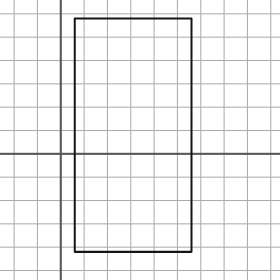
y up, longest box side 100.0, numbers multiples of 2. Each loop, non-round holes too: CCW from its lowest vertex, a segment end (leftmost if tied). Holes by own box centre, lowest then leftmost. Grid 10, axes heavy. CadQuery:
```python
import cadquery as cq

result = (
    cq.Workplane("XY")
    .moveTo(6.0, -42.0)
    .lineTo(56.0, -42.0)
    .lineTo(56.0, 58.0)
    .lineTo(6.0, 58.0)
    .close()
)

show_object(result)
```